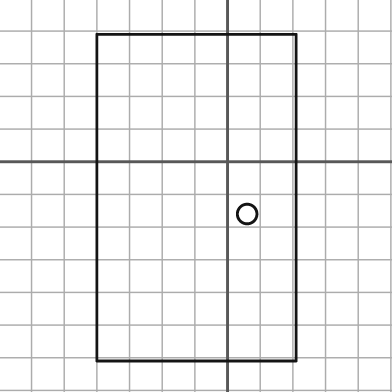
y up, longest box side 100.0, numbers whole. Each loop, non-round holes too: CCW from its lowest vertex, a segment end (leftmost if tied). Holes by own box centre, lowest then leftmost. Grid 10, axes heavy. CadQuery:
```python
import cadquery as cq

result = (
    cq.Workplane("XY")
    .moveTo(-40.0, -61.0)
    .lineTo(21.0, -61.0)
    .lineTo(21.0, 39.0)
    .lineTo(-40.0, 39.0)
    .close()
    .moveTo(6.0, -16.0)
    .circle(3.0)
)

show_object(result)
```